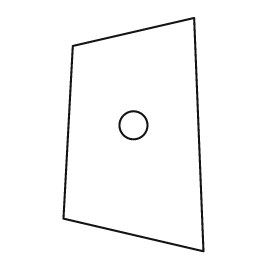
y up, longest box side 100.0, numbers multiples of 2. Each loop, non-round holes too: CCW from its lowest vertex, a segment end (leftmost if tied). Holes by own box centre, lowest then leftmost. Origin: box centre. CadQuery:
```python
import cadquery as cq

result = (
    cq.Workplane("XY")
    .moveTo(30.0, -50.0)
    .lineTo(26.0, 50.0)
    .lineTo(-26.0, 38.0)
    .lineTo(-30.0, -36.0)
    .close()
    .moveTo(0.0, 4.0)
    .circle(6.0)
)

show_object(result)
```